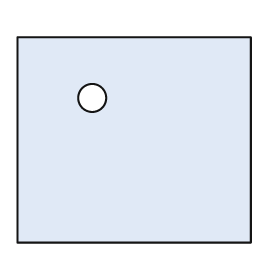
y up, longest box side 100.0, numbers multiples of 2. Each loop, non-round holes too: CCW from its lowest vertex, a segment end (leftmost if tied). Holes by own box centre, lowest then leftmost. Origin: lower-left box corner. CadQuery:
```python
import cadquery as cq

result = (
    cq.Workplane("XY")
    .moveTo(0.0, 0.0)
    .lineTo(100.0, 0.0)
    .lineTo(100.0, 88.0)
    .lineTo(0.0, 88.0)
    .close()
    .moveTo(32.0, 62.0)
    .circle(6.0)
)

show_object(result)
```